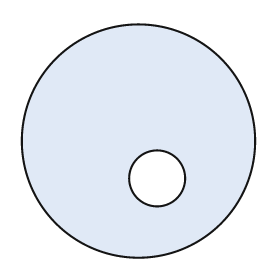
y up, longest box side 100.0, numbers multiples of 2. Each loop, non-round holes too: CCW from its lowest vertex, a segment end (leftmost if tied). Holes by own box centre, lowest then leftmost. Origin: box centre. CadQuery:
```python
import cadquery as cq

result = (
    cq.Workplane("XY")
    .moveTo(0.0, 0.0)
    .circle(50.0)
    .moveTo(8.0, -16.0)
    .circle(12.0)
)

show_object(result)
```